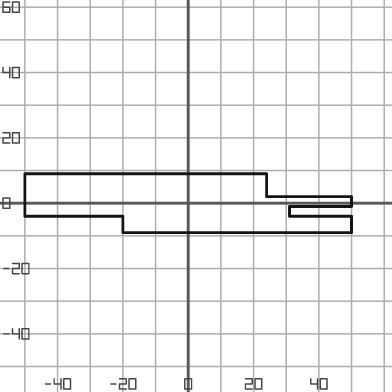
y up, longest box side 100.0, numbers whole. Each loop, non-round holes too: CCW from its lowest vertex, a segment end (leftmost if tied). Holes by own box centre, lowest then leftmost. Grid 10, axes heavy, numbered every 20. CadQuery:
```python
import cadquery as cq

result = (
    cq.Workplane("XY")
    .moveTo(-20.0, -9.0)
    .lineTo(50.0, -9.0)
    .lineTo(50.0, -4.0)
    .lineTo(31.0, -4.0)
    .lineTo(31.0, -1.0)
    .lineTo(50.0, -1.0)
    .lineTo(50.0, 2.0)
    .lineTo(24.0, 2.0)
    .lineTo(24.0, 9.0)
    .lineTo(-50.0, 9.0)
    .lineTo(-50.0, -4.0)
    .lineTo(-20.0, -4.0)
    .close()
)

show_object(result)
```